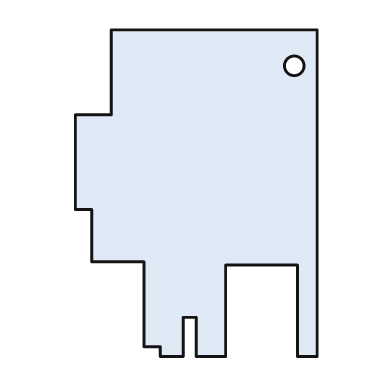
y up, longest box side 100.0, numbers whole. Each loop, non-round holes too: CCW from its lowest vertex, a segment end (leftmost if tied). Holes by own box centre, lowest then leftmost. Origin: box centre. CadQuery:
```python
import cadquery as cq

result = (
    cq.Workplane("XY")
    .moveTo(-11.0, -50.0)
    .lineTo(-4.0, -50.0)
    .lineTo(-4.0, -38.0)
    .lineTo(0.0, -38.0)
    .lineTo(0.0, -50.0)
    .lineTo(9.0, -50.0)
    .lineTo(9.0, -22.0)
    .lineTo(31.0, -22.0)
    .lineTo(31.0, -50.0)
    .lineTo(37.0, -50.0)
    .lineTo(37.0, 50.0)
    .lineTo(-26.0, 50.0)
    .lineTo(-26.0, 24.0)
    .lineTo(-37.0, 24.0)
    .lineTo(-37.0, -5.0)
    .lineTo(-32.0, -5.0)
    .lineTo(-32.0, -21.0)
    .lineTo(-16.0, -21.0)
    .lineTo(-16.0, -47.0)
    .lineTo(-11.0, -47.0)
    .close()
    .moveTo(30.0, 39.0)
    .circle(3.0)
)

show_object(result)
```